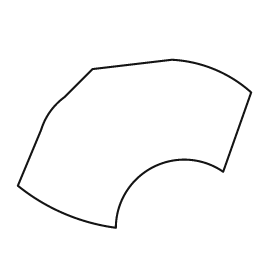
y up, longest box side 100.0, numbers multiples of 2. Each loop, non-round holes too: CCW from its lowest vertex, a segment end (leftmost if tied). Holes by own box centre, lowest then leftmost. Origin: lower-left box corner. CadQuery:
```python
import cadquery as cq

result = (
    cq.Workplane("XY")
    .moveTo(42.0, 0.0)
    .threePointArc((58.0, 26.0), (88.0, 24.0))
    .lineTo(100.0, 58.0)
    .threePointArc((84.0, 68.0), (66.0, 72.0))
    .lineTo(32.0, 68.0)
    .lineTo(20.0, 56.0)
    .threePointArc((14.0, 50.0), (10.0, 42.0))
    .lineTo(0.0, 18.0)
    .threePointArc((20.0, 6.0), (42.0, 0.0))
    .close()
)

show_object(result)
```